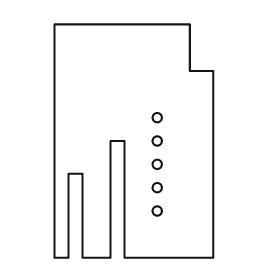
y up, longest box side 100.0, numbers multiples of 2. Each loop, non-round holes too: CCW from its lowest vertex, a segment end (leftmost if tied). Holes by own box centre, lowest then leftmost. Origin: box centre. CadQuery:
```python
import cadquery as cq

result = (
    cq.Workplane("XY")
    .moveTo(-34.0, -50.0)
    .lineTo(-28.0, -50.0)
    .lineTo(-28.0, -14.0)
    .lineTo(-22.0, -14.0)
    .lineTo(-22.0, -50.0)
    .lineTo(-10.0, -50.0)
    .lineTo(-10.0, 0.0)
    .lineTo(-4.0, 0.0)
    .lineTo(-4.0, -50.0)
    .lineTo(34.0, -50.0)
    .lineTo(34.0, 30.0)
    .lineTo(24.0, 30.0)
    .lineTo(24.0, 50.0)
    .lineTo(-34.0, 50.0)
    .close()
    .moveTo(10.0, -30.0)
    .circle(2.0)
    .moveTo(10.0, -20.0)
    .circle(2.0)
    .moveTo(10.0, -10.0)
    .circle(2.0)
    .moveTo(10.0, 0.0)
    .circle(2.0)
    .moveTo(10.0, 10.0)
    .circle(2.0)
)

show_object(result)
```